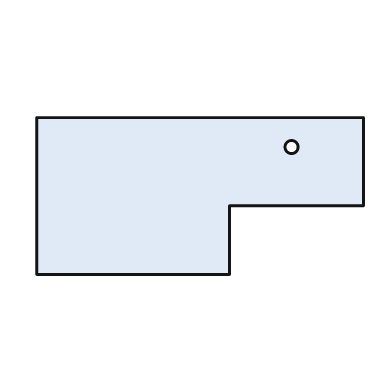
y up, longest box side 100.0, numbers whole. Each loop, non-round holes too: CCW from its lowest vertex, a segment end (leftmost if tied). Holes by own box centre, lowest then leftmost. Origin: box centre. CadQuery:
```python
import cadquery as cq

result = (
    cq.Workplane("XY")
    .moveTo(-50.0, -24.0)
    .lineTo(9.0, -24.0)
    .lineTo(9.0, -3.0)
    .lineTo(50.0, -3.0)
    .lineTo(50.0, 24.0)
    .lineTo(-50.0, 24.0)
    .close()
    .moveTo(28.0, 15.0)
    .circle(2.0)
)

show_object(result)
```